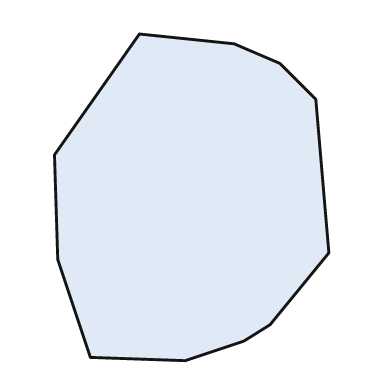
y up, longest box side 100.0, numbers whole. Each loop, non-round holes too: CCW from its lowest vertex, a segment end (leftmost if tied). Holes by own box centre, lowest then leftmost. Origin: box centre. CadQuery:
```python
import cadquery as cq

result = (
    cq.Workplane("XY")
    .moveTo(-2.0, -50.0)
    .lineTo(16.0, -44.0)
    .lineTo(24.0, -39.0)
    .lineTo(42.0, -17.0)
    .lineTo(38.0, 30.0)
    .lineTo(27.0, 41.0)
    .lineTo(13.0, 47.0)
    .lineTo(-16.0, 50.0)
    .lineTo(-42.0, 13.0)
    .lineTo(-41.0, -19.0)
    .lineTo(-31.0, -49.0)
    .close()
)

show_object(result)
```